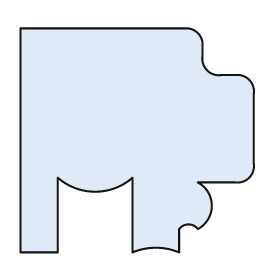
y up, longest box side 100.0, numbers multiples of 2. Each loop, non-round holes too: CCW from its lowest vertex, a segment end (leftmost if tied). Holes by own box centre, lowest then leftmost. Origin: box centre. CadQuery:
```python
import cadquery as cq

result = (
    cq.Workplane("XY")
    .moveTo(-50.0, -48.0)
    .lineTo(-34.0, -48.0)
    .lineTo(-34.0, -16.0)
    .threePointArc((-18.0, -22.0), (-2.0, -16.0))
    .lineTo(-2.0, -48.0)
    .threePointArc((8.0, -46.0), (18.0, -48.0))
    .lineTo(18.0, -38.0)
    .threePointArc((22.0, -36.0), (26.0, -38.0))
    .threePointArc((32.0, -28.0), (26.0, -18.0))
    .lineTo(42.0, -18.0)
    .threePointArc((48.0, -16.0), (50.0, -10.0))
    .lineTo(50.0, 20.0)
    .threePointArc((48.0, 26.0), (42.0, 28.0))
    .lineTo(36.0, 28.0)
    .threePointArc((30.0, 30.0), (28.0, 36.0))
    .lineTo(28.0, 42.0)
    .threePointArc((26.0, 46.0), (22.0, 48.0))
    .lineTo(-50.0, 48.0)
    .close()
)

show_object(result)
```